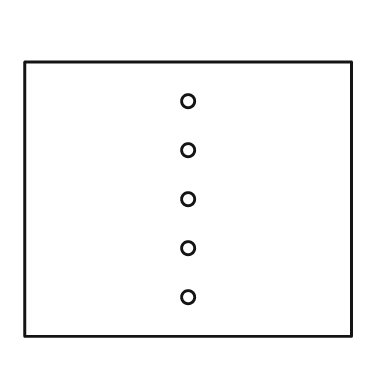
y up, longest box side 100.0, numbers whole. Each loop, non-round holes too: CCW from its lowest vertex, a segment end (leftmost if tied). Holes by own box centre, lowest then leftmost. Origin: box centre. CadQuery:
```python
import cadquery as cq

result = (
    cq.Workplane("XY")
    .moveTo(-50.0, -42.0)
    .lineTo(50.0, -42.0)
    .lineTo(50.0, 42.0)
    .lineTo(-50.0, 42.0)
    .close()
    .moveTo(0.0, -30.0)
    .circle(2.0)
    .moveTo(0.0, -15.0)
    .circle(2.0)
    .moveTo(0.0, 0.0)
    .circle(2.0)
    .moveTo(0.0, 15.0)
    .circle(2.0)
    .moveTo(0.0, 30.0)
    .circle(2.0)
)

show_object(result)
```